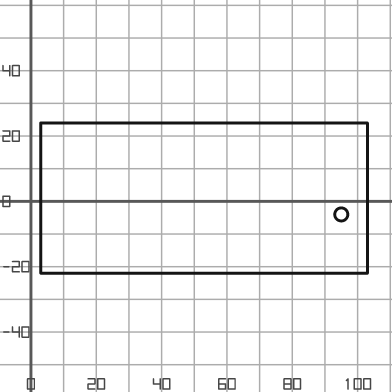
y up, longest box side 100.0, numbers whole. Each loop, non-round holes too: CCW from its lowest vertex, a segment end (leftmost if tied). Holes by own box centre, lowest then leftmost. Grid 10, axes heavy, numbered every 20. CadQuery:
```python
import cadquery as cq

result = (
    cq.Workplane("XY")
    .moveTo(3.0, -22.0)
    .lineTo(103.0, -22.0)
    .lineTo(103.0, 24.0)
    .lineTo(3.0, 24.0)
    .close()
    .moveTo(95.0, -4.0)
    .circle(2.0)
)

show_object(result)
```